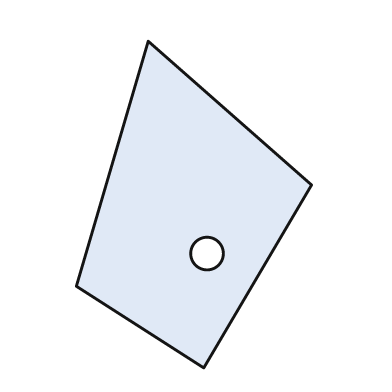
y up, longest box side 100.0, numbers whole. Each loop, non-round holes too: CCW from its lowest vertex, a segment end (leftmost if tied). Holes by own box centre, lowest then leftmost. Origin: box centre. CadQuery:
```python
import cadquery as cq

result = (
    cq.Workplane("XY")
    .moveTo(3.0, -50.0)
    .lineTo(36.0, 6.0)
    .lineTo(-14.0, 50.0)
    .lineTo(-36.0, -25.0)
    .close()
    .moveTo(4.0, -15.0)
    .circle(5.0)
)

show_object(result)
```